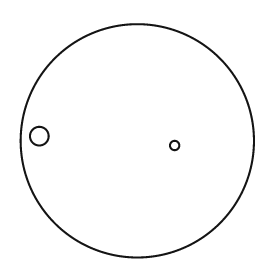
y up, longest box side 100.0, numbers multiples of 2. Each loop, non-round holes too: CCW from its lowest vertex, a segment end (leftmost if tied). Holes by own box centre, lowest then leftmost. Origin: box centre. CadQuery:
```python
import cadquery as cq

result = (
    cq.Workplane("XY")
    .moveTo(0.0, 0.0)
    .circle(50.0)
    .moveTo(16.0, -2.0)
    .circle(2.0)
    .moveTo(-42.0, 2.0)
    .circle(4.0)
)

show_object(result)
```